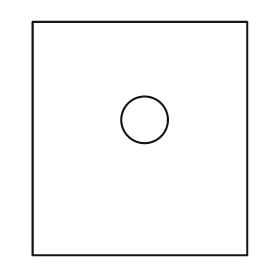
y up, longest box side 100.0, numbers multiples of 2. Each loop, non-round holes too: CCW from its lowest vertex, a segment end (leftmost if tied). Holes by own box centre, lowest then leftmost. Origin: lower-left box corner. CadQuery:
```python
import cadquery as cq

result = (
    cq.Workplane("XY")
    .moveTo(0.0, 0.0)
    .lineTo(92.0, 0.0)
    .lineTo(92.0, 100.0)
    .lineTo(0.0, 100.0)
    .close()
    .moveTo(48.0, 58.0)
    .circle(10.0)
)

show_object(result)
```